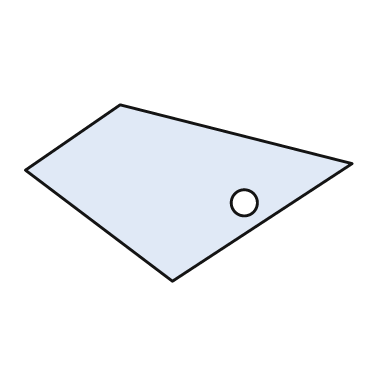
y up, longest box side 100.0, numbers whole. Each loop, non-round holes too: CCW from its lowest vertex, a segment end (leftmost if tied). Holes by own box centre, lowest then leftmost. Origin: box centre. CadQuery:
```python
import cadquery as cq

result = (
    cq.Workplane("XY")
    .moveTo(-5.0, -27.0)
    .lineTo(50.0, 9.0)
    .lineTo(-21.0, 27.0)
    .lineTo(-50.0, 7.0)
    .close()
    .moveTo(17.0, -3.0)
    .circle(4.0)
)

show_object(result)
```